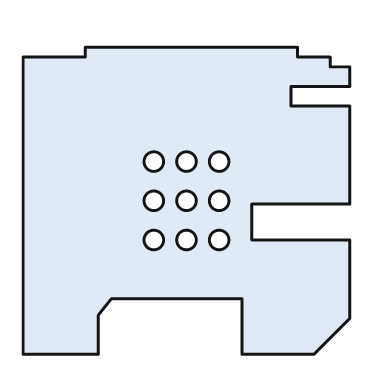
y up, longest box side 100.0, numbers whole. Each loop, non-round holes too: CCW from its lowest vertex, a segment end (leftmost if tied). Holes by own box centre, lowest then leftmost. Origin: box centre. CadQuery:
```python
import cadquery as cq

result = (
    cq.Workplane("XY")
    .moveTo(-50.0, -47.0)
    .lineTo(-27.0, -47.0)
    .lineTo(-27.0, -35.0)
    .lineTo(-23.0, -30.0)
    .lineTo(17.0, -30.0)
    .lineTo(17.0, -47.0)
    .lineTo(39.0, -47.0)
    .lineTo(50.0, -36.0)
    .lineTo(50.0, -12.0)
    .lineTo(20.0, -12.0)
    .lineTo(20.0, -1.0)
    .lineTo(50.0, -1.0)
    .lineTo(50.0, 29.0)
    .lineTo(32.0, 29.0)
    .lineTo(32.0, 35.0)
    .lineTo(50.0, 35.0)
    .lineTo(50.0, 41.0)
    .lineTo(44.0, 41.0)
    .lineTo(44.0, 44.0)
    .lineTo(34.0, 44.0)
    .lineTo(34.0, 47.0)
    .lineTo(-31.0, 47.0)
    .lineTo(-31.0, 44.0)
    .lineTo(-50.0, 44.0)
    .close()
    .moveTo(-10.0, -12.0)
    .circle(3.0)
    .moveTo(0.0, -12.0)
    .circle(3.0)
    .moveTo(10.0, -12.0)
    .circle(3.0)
    .moveTo(-10.0, 0.0)
    .circle(3.0)
    .moveTo(0.0, 0.0)
    .circle(3.0)
    .moveTo(10.0, 0.0)
    .circle(3.0)
    .moveTo(-10.0, 12.0)
    .circle(3.0)
    .moveTo(0.0, 12.0)
    .circle(3.0)
    .moveTo(10.0, 12.0)
    .circle(3.0)
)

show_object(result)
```